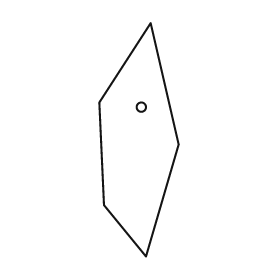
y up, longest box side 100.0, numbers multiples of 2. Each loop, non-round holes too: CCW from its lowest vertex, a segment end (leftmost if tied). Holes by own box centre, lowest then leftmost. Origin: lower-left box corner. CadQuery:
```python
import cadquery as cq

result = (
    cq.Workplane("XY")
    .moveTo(20.0, 0.0)
    .lineTo(34.0, 48.0)
    .lineTo(22.0, 100.0)
    .lineTo(0.0, 66.0)
    .lineTo(2.0, 22.0)
    .close()
    .moveTo(18.0, 64.0)
    .circle(2.0)
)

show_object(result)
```